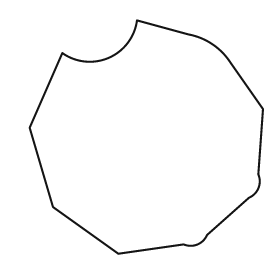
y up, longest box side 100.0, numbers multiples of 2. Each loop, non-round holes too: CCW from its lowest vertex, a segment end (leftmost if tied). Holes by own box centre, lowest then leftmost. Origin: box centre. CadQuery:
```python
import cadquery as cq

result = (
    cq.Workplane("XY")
    .moveTo(-12.0, -50.0)
    .lineTo(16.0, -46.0)
    .threePointArc((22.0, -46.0), (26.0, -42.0))
    .lineTo(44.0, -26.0)
    .threePointArc((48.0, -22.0), (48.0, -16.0))
    .lineTo(50.0, 12.0)
    .lineTo(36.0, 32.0)
    .threePointArc((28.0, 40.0), (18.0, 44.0))
    .lineTo(-4.0, 50.0)
    .threePointArc((-16.0, 34.0), (-36.0, 36.0))
    .lineTo(-50.0, 4.0)
    .lineTo(-40.0, -30.0)
    .close()
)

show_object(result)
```